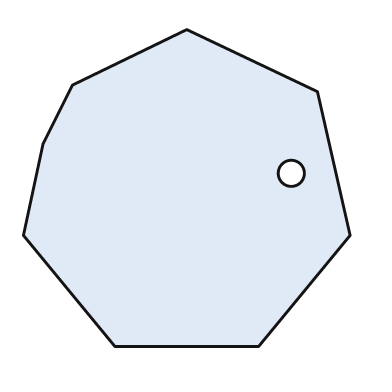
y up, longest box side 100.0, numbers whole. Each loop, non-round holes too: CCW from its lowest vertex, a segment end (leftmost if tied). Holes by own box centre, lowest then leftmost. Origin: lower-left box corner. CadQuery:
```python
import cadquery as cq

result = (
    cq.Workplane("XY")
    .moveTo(28.0, 0.0)
    .lineTo(72.0, 0.0)
    .lineTo(100.0, 34.0)
    .lineTo(90.0, 78.0)
    .lineTo(50.0, 97.0)
    .lineTo(15.0, 80.0)
    .lineTo(6.0, 62.0)
    .lineTo(0.0, 34.0)
    .close()
    .moveTo(82.0, 53.0)
    .circle(4.0)
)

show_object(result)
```